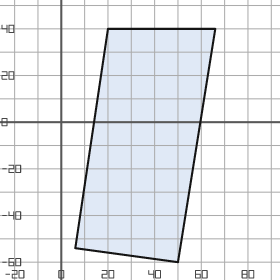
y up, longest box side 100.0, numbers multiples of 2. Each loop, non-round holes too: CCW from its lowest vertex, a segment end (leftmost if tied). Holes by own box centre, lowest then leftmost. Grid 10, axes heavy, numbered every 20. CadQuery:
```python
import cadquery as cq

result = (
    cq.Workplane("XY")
    .moveTo(50.0, -60.0)
    .lineTo(66.0, 40.0)
    .lineTo(20.0, 40.0)
    .lineTo(6.0, -54.0)
    .close()
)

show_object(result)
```